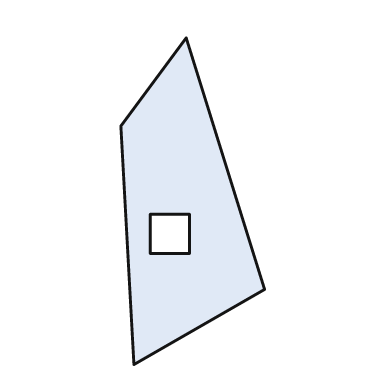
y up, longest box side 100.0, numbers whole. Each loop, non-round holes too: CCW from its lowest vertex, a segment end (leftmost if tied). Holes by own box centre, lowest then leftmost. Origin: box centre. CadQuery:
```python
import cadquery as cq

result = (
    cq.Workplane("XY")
    .moveTo(-18.0, -50.0)
    .lineTo(22.0, -27.0)
    .lineTo(-2.0, 50.0)
    .lineTo(-22.0, 23.0)
    .close()
    .moveTo(-13.0, -16.0)
    .lineTo(-1.0, -16.0)
    .lineTo(-1.0, -4.0)
    .lineTo(-13.0, -4.0)
    .close()
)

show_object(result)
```